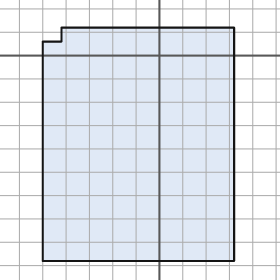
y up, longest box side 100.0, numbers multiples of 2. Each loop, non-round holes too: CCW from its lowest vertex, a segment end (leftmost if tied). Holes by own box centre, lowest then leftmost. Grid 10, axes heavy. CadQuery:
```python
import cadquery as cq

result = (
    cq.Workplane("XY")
    .moveTo(-50.0, -88.0)
    .lineTo(32.0, -88.0)
    .lineTo(32.0, 12.0)
    .lineTo(-42.0, 12.0)
    .lineTo(-42.0, 6.0)
    .lineTo(-50.0, 6.0)
    .close()
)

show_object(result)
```